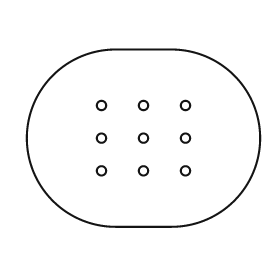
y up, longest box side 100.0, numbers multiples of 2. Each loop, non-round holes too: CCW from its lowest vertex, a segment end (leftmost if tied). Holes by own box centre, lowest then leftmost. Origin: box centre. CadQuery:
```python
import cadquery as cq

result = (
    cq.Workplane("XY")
    .moveTo(-12.0, -38.0)
    .lineTo(12.0, -38.0)
    .threePointArc((50.0, 0.0), (12.0, 38.0))
    .lineTo(-12.0, 38.0)
    .threePointArc((-50.0, 0.0), (-12.0, -38.0))
    .close()
    .moveTo(-18.0, -14.0)
    .circle(2.0)
    .moveTo(0.0, -14.0)
    .circle(2.0)
    .moveTo(18.0, -14.0)
    .circle(2.0)
    .moveTo(-18.0, 0.0)
    .circle(2.0)
    .moveTo(0.0, 0.0)
    .circle(2.0)
    .moveTo(18.0, 0.0)
    .circle(2.0)
    .moveTo(-18.0, 14.0)
    .circle(2.0)
    .moveTo(0.0, 14.0)
    .circle(2.0)
    .moveTo(18.0, 14.0)
    .circle(2.0)
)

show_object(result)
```